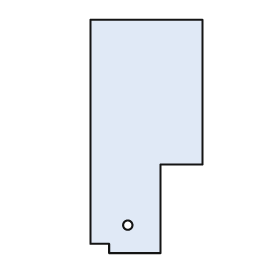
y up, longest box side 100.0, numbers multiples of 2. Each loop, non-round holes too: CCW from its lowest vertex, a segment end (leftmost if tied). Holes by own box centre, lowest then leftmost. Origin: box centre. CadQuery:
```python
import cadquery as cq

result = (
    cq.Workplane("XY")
    .moveTo(-16.0, -50.0)
    .lineTo(6.0, -50.0)
    .lineTo(6.0, -12.0)
    .lineTo(24.0, -12.0)
    .lineTo(24.0, 50.0)
    .lineTo(-24.0, 50.0)
    .lineTo(-24.0, -46.0)
    .lineTo(-16.0, -46.0)
    .close()
    .moveTo(-8.0, -38.0)
    .circle(2.0)
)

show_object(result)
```